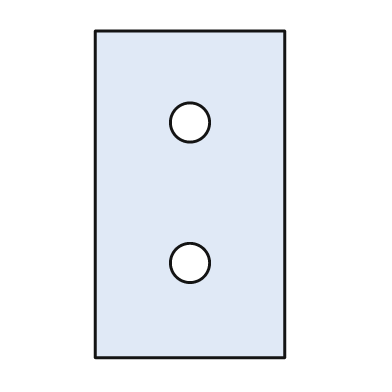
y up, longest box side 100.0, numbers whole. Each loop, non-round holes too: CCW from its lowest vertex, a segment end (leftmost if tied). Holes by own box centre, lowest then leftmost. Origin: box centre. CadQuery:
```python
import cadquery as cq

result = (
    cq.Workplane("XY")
    .moveTo(-29.0, -50.0)
    .lineTo(29.0, -50.0)
    .lineTo(29.0, 50.0)
    .lineTo(-29.0, 50.0)
    .close()
    .moveTo(0.0, -21.0)
    .circle(6.0)
    .moveTo(0.0, 22.0)
    .circle(6.0)
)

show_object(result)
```